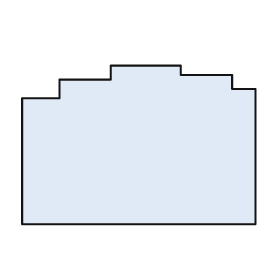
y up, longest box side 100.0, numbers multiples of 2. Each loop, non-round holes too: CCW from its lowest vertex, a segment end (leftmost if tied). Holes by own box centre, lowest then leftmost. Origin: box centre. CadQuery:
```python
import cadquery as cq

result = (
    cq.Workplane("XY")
    .moveTo(-50.0, -34.0)
    .lineTo(50.0, -34.0)
    .lineTo(50.0, 24.0)
    .lineTo(40.0, 24.0)
    .lineTo(40.0, 30.0)
    .lineTo(18.0, 30.0)
    .lineTo(18.0, 34.0)
    .lineTo(-12.0, 34.0)
    .lineTo(-12.0, 28.0)
    .lineTo(-34.0, 28.0)
    .lineTo(-34.0, 20.0)
    .lineTo(-50.0, 20.0)
    .close()
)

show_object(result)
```